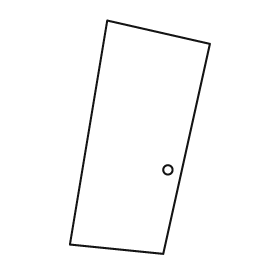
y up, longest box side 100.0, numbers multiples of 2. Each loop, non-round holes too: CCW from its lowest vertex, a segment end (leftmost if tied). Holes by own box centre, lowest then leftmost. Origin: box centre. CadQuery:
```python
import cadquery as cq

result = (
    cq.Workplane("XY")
    .moveTo(10.0, -50.0)
    .lineTo(30.0, 40.0)
    .lineTo(-14.0, 50.0)
    .lineTo(-30.0, -46.0)
    .close()
    .moveTo(12.0, -14.0)
    .circle(2.0)
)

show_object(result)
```